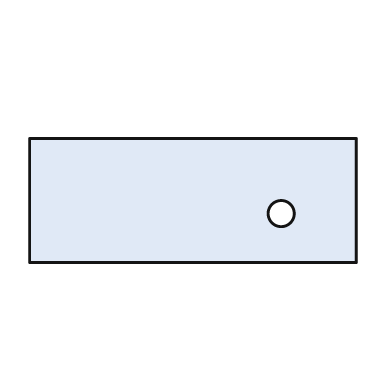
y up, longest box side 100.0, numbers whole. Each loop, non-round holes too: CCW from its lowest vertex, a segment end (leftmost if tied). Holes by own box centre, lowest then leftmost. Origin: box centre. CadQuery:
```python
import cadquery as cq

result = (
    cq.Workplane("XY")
    .moveTo(-50.0, -19.0)
    .lineTo(50.0, -19.0)
    .lineTo(50.0, 19.0)
    .lineTo(-50.0, 19.0)
    .close()
    .moveTo(27.0, -4.0)
    .circle(4.0)
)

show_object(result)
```